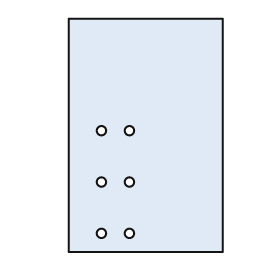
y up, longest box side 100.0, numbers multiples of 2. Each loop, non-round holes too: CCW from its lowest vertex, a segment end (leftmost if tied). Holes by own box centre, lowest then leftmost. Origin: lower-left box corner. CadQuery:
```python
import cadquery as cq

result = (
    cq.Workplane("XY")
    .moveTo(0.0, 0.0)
    .lineTo(66.0, 0.0)
    .lineTo(66.0, 100.0)
    .lineTo(0.0, 100.0)
    .close()
    .moveTo(14.0, 8.0)
    .circle(2.0)
    .moveTo(26.0, 8.0)
    .circle(2.0)
    .moveTo(14.0, 30.0)
    .circle(2.0)
    .moveTo(26.0, 30.0)
    .circle(2.0)
    .moveTo(14.0, 52.0)
    .circle(2.0)
    .moveTo(26.0, 52.0)
    .circle(2.0)
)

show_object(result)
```